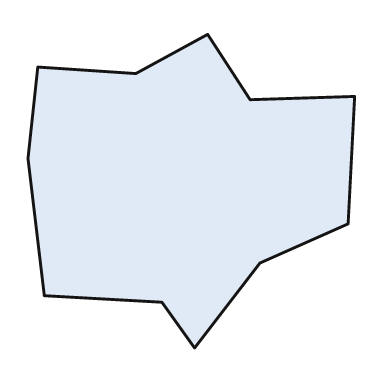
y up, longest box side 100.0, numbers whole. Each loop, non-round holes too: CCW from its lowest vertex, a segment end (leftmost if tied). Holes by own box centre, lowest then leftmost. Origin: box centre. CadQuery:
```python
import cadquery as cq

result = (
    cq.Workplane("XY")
    .moveTo(1.0, -48.0)
    .lineTo(21.0, -22.0)
    .lineTo(48.0, -10.0)
    .lineTo(50.0, 29.0)
    .lineTo(18.0, 28.0)
    .lineTo(5.0, 48.0)
    .lineTo(-17.0, 36.0)
    .lineTo(-47.0, 38.0)
    .lineTo(-50.0, 10.0)
    .lineTo(-45.0, -32.0)
    .lineTo(-9.0, -34.0)
    .close()
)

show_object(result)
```